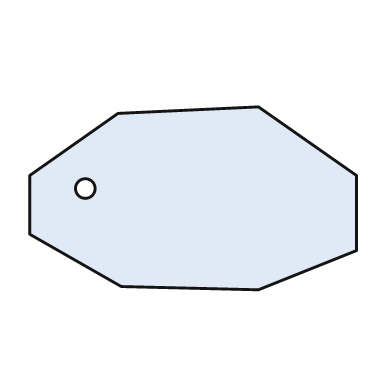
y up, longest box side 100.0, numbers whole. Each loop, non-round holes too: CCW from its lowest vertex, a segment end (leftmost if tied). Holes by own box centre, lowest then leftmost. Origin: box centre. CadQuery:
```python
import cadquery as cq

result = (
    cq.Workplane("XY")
    .moveTo(20.0, -28.0)
    .lineTo(50.0, -16.0)
    .lineTo(50.0, 7.0)
    .lineTo(20.0, 28.0)
    .lineTo(-23.0, 26.0)
    .lineTo(-50.0, 7.0)
    .lineTo(-50.0, -11.0)
    .lineTo(-22.0, -27.0)
    .close()
    .moveTo(-33.0, 3.0)
    .circle(3.0)
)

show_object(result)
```